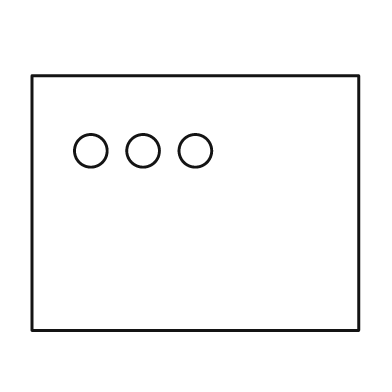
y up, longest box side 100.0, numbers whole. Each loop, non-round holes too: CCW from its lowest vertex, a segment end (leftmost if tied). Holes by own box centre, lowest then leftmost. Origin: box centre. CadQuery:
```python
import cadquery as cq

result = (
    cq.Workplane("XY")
    .moveTo(-50.0, -39.0)
    .lineTo(50.0, -39.0)
    .lineTo(50.0, 39.0)
    .lineTo(-50.0, 39.0)
    .close()
    .moveTo(-32.0, 16.0)
    .circle(5.0)
    .moveTo(-16.0, 16.0)
    .circle(5.0)
    .moveTo(0.0, 16.0)
    .circle(5.0)
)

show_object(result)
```